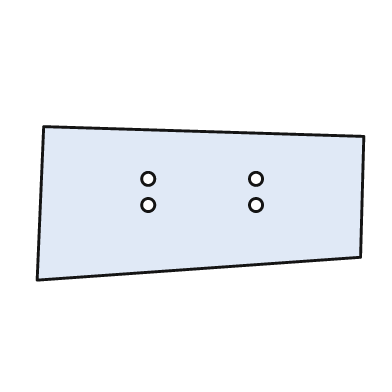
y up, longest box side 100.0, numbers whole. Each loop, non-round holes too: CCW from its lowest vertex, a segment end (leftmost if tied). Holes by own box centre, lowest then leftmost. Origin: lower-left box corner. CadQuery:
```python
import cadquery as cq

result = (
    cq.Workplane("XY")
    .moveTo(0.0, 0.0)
    .lineTo(99.0, 7.0)
    .lineTo(100.0, 44.0)
    .lineTo(2.0, 47.0)
    .close()
    .moveTo(34.0, 23.0)
    .circle(2.0)
    .moveTo(67.0, 23.0)
    .circle(2.0)
    .moveTo(34.0, 31.0)
    .circle(2.0)
    .moveTo(67.0, 31.0)
    .circle(2.0)
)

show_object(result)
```